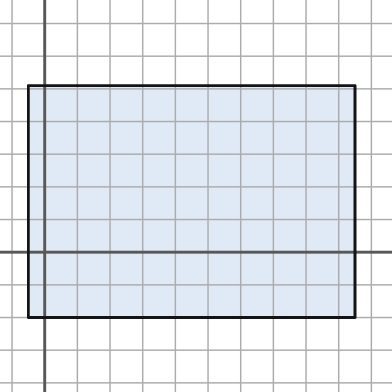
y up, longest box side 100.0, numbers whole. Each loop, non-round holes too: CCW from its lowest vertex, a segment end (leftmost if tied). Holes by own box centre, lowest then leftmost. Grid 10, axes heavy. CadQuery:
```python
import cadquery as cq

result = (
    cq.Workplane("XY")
    .moveTo(-5.0, -20.0)
    .lineTo(95.0, -20.0)
    .lineTo(95.0, 51.0)
    .lineTo(-5.0, 51.0)
    .close()
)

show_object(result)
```